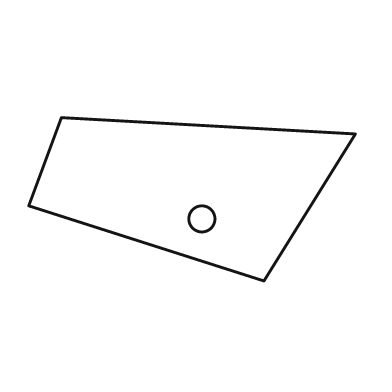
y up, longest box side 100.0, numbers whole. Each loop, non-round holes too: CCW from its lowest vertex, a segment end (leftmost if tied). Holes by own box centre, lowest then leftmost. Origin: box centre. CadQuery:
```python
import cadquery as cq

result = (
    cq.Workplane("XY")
    .moveTo(22.0, -25.0)
    .lineTo(50.0, 20.0)
    .lineTo(-40.0, 25.0)
    .lineTo(-50.0, -2.0)
    .close()
    .moveTo(3.0, -6.0)
    .circle(4.0)
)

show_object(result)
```